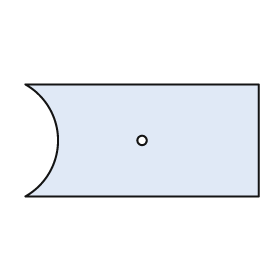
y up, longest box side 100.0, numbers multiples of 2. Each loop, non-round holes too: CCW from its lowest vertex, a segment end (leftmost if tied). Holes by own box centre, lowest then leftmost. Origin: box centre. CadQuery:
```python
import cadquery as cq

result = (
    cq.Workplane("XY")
    .moveTo(-50.0, -24.0)
    .lineTo(50.0, -24.0)
    .lineTo(50.0, 24.0)
    .lineTo(-50.0, 24.0)
    .threePointArc((-36.0, 0.0), (-50.0, -24.0))
    .close()
    .moveTo(0.0, 0.0)
    .circle(2.0)
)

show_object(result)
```